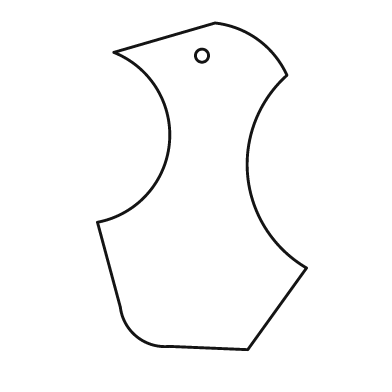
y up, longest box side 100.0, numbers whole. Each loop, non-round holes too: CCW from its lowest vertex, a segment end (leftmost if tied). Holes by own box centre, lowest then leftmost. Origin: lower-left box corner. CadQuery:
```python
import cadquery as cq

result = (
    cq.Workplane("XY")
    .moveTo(46.0, 0.0)
    .lineTo(64.0, 25.0)
    .threePointArc((46.0, 53.0), (58.0, 84.0))
    .threePointArc((49.0, 95.0), (36.0, 100.0))
    .lineTo(5.0, 91.0)
    .threePointArc((22.0, 63.0), (0.0, 39.0))
    .lineTo(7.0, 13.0)
    .threePointArc((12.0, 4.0), (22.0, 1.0))
    .close()
    .moveTo(32.0, 90.0)
    .circle(2.0)
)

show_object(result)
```